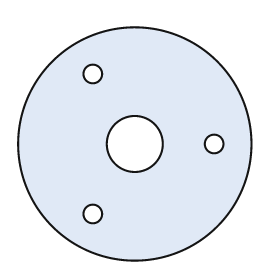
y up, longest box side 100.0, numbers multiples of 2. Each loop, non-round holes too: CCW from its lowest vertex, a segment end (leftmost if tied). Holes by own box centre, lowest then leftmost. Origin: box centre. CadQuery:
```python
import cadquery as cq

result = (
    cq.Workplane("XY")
    .moveTo(0.0, 0.0)
    .circle(50.0)
    .moveTo(-18.0, -30.0)
    .circle(4.0)
    .moveTo(0.0, 0.0)
    .circle(12.0)
    .moveTo(34.0, 0.0)
    .circle(4.0)
    .moveTo(-18.0, 30.0)
    .circle(4.0)
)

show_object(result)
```